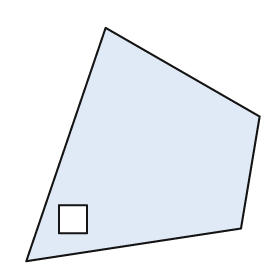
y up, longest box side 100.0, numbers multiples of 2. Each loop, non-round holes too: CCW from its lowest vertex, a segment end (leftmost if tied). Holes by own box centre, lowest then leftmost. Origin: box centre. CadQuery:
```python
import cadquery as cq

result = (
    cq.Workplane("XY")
    .moveTo(-50.0, -50.0)
    .lineTo(42.0, -36.0)
    .lineTo(50.0, 12.0)
    .lineTo(-16.0, 50.0)
    .close()
    .moveTo(-36.0, -38.0)
    .lineTo(-24.0, -38.0)
    .lineTo(-24.0, -26.0)
    .lineTo(-36.0, -26.0)
    .close()
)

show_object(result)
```